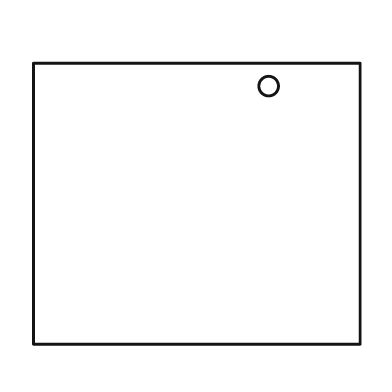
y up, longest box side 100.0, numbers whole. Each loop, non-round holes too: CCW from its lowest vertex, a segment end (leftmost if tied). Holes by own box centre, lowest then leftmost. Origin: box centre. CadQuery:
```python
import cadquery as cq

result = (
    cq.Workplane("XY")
    .moveTo(-50.0, -43.0)
    .lineTo(50.0, -43.0)
    .lineTo(50.0, 43.0)
    .lineTo(-50.0, 43.0)
    .close()
    .moveTo(22.0, 36.0)
    .circle(3.0)
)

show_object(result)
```